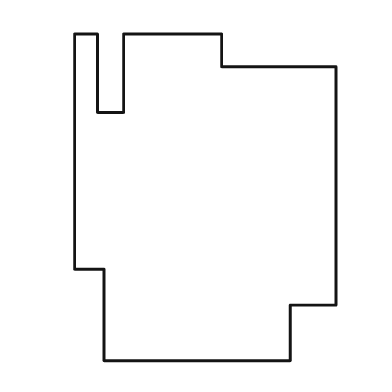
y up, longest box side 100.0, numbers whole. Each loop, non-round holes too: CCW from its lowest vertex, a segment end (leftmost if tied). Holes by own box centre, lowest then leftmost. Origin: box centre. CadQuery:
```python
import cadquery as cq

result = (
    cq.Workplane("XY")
    .moveTo(-31.0, -50.0)
    .lineTo(26.0, -50.0)
    .lineTo(26.0, -33.0)
    .lineTo(40.0, -33.0)
    .lineTo(40.0, 40.0)
    .lineTo(5.0, 40.0)
    .lineTo(5.0, 50.0)
    .lineTo(-25.0, 50.0)
    .lineTo(-25.0, 26.0)
    .lineTo(-33.0, 26.0)
    .lineTo(-33.0, 50.0)
    .lineTo(-40.0, 50.0)
    .lineTo(-40.0, -22.0)
    .lineTo(-31.0, -22.0)
    .close()
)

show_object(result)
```